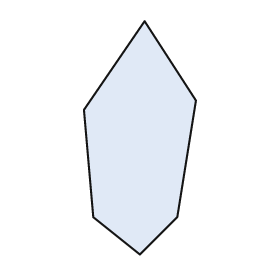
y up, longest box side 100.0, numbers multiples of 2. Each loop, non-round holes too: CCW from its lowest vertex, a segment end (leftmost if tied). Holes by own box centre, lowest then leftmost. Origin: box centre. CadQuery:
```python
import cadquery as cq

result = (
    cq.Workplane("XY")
    .moveTo(0.0, -50.0)
    .lineTo(16.0, -34.0)
    .lineTo(24.0, 16.0)
    .lineTo(2.0, 50.0)
    .lineTo(-24.0, 12.0)
    .lineTo(-20.0, -34.0)
    .close()
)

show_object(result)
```